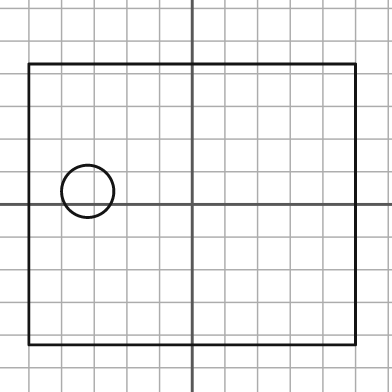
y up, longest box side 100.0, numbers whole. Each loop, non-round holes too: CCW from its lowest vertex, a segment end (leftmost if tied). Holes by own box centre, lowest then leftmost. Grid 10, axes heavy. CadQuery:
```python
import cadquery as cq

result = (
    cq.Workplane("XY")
    .moveTo(-50.0, -43.0)
    .lineTo(50.0, -43.0)
    .lineTo(50.0, 43.0)
    .lineTo(-50.0, 43.0)
    .close()
    .moveTo(-32.0, 4.0)
    .circle(8.0)
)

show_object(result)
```